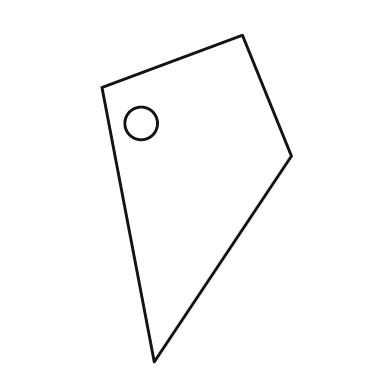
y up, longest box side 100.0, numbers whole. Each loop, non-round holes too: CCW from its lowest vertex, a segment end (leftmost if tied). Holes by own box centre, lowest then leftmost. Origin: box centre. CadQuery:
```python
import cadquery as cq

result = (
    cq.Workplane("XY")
    .moveTo(-13.0, -50.0)
    .lineTo(29.0, 13.0)
    .lineTo(14.0, 50.0)
    .lineTo(-29.0, 34.0)
    .close()
    .moveTo(-17.0, 23.0)
    .circle(5.0)
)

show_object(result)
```